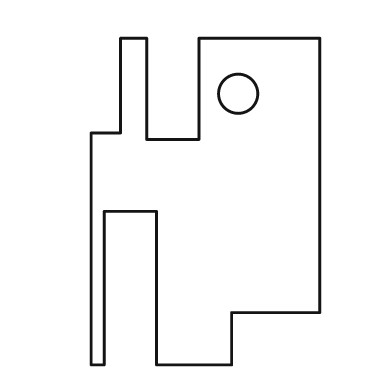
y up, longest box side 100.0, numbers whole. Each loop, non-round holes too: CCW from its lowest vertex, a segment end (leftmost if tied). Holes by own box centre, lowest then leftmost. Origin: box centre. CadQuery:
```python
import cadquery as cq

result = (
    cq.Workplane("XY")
    .moveTo(-35.0, -50.0)
    .lineTo(-31.0, -50.0)
    .lineTo(-31.0, -3.0)
    .lineTo(-15.0, -3.0)
    .lineTo(-15.0, -50.0)
    .lineTo(8.0, -50.0)
    .lineTo(8.0, -34.0)
    .lineTo(35.0, -34.0)
    .lineTo(35.0, 50.0)
    .lineTo(-2.0, 50.0)
    .lineTo(-2.0, 19.0)
    .lineTo(-18.0, 19.0)
    .lineTo(-18.0, 50.0)
    .lineTo(-26.0, 50.0)
    .lineTo(-26.0, 21.0)
    .lineTo(-35.0, 21.0)
    .close()
    .moveTo(10.0, 33.0)
    .circle(6.0)
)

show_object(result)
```